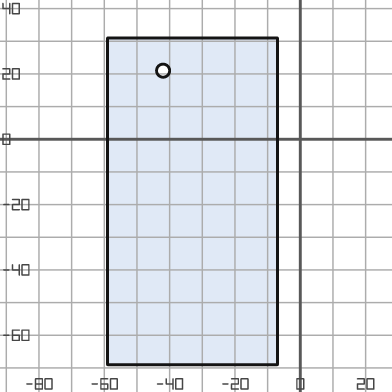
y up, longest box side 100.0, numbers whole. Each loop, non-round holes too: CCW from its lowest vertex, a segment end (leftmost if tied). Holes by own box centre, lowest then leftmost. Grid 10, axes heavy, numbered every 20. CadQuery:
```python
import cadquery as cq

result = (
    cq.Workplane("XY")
    .moveTo(-59.0, -69.0)
    .lineTo(-7.0, -69.0)
    .lineTo(-7.0, 31.0)
    .lineTo(-59.0, 31.0)
    .close()
    .moveTo(-42.0, 21.0)
    .circle(2.0)
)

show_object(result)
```